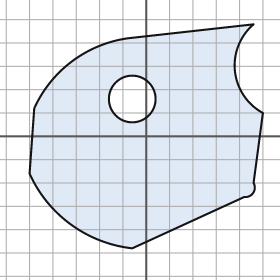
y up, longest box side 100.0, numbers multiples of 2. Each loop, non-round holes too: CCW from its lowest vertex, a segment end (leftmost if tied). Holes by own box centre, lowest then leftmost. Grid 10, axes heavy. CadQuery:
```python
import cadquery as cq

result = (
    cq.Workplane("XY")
    .moveTo(-6.0, -48.0)
    .lineTo(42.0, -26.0)
    .threePointArc((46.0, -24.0), (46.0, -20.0))
    .lineTo(50.0, 10.0)
    .threePointArc((38.0, 28.0), (46.0, 48.0))
    .lineTo(-8.0, 42.0)
    .threePointArc((-32.0, 32.0), (-48.0, 12.0))
    .lineTo(-50.0, -16.0)
    .threePointArc((-32.0, -38.0), (-6.0, -48.0))
    .close()
    .moveTo(-6.0, 16.0)
    .circle(10.0)
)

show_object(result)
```